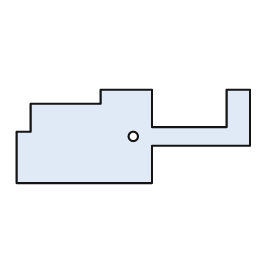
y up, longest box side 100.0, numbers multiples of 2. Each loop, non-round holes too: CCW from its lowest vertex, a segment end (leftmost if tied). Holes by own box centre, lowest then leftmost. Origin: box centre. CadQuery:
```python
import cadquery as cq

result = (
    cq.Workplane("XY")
    .moveTo(-50.0, -20.0)
    .lineTo(8.0, -20.0)
    .lineTo(8.0, -4.0)
    .lineTo(50.0, -4.0)
    .lineTo(50.0, 20.0)
    .lineTo(40.0, 20.0)
    .lineTo(40.0, 4.0)
    .lineTo(8.0, 4.0)
    .lineTo(8.0, 20.0)
    .lineTo(-14.0, 20.0)
    .lineTo(-14.0, 14.0)
    .lineTo(-44.0, 14.0)
    .lineTo(-44.0, 2.0)
    .lineTo(-50.0, 2.0)
    .close()
    .moveTo(0.0, 0.0)
    .circle(2.0)
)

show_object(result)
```